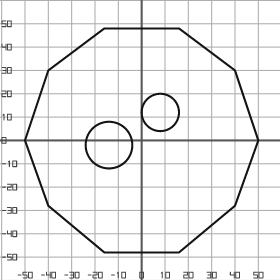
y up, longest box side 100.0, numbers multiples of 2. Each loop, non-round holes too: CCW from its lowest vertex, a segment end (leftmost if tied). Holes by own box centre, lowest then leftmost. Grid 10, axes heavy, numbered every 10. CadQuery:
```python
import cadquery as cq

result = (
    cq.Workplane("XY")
    .moveTo(-16.0, -48.0)
    .lineTo(16.0, -48.0)
    .lineTo(40.0, -28.0)
    .lineTo(50.0, 0.0)
    .lineTo(40.0, 30.0)
    .lineTo(16.0, 48.0)
    .lineTo(-16.0, 48.0)
    .lineTo(-40.0, 30.0)
    .lineTo(-50.0, 0.0)
    .lineTo(-40.0, -28.0)
    .close()
    .moveTo(-14.0, -2.0)
    .circle(10.0)
    .moveTo(8.0, 12.0)
    .circle(8.0)
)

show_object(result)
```